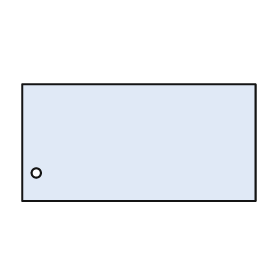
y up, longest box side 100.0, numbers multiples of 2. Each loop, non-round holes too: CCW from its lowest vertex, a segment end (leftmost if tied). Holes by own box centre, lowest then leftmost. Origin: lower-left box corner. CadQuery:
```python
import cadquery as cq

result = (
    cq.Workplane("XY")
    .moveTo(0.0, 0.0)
    .lineTo(100.0, 0.0)
    .lineTo(100.0, 50.0)
    .lineTo(0.0, 50.0)
    .close()
    .moveTo(6.0, 12.0)
    .circle(2.0)
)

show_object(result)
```